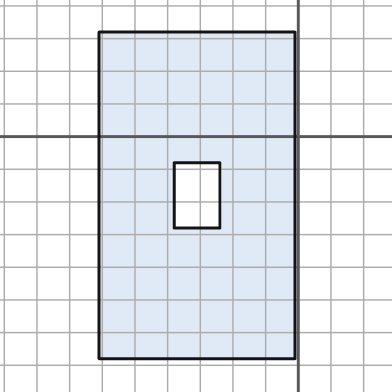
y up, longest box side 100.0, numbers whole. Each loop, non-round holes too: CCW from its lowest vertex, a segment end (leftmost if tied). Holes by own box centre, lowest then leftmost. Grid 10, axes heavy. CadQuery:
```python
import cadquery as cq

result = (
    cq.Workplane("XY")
    .moveTo(-61.0, -68.0)
    .lineTo(-1.0, -68.0)
    .lineTo(-1.0, 32.0)
    .lineTo(-61.0, 32.0)
    .close()
    .moveTo(-38.0, -28.0)
    .lineTo(-24.0, -28.0)
    .lineTo(-24.0, -8.0)
    .lineTo(-38.0, -8.0)
    .close()
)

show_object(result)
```